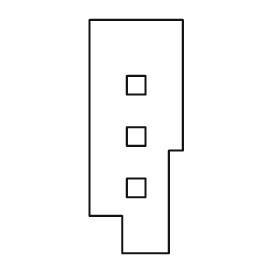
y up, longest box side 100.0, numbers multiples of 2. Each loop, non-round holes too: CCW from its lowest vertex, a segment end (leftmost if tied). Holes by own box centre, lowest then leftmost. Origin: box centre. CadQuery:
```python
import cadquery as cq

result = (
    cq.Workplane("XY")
    .moveTo(-6.0, -50.0)
    .lineTo(14.0, -50.0)
    .lineTo(14.0, -6.0)
    .lineTo(20.0, -6.0)
    .lineTo(20.0, 50.0)
    .lineTo(-20.0, 50.0)
    .lineTo(-20.0, -34.0)
    .lineTo(-6.0, -34.0)
    .close()
    .moveTo(-4.0, -26.0)
    .lineTo(4.0, -26.0)
    .lineTo(4.0, -18.0)
    .lineTo(-4.0, -18.0)
    .close()
    .moveTo(-4.0, -4.0)
    .lineTo(4.0, -4.0)
    .lineTo(4.0, 4.0)
    .lineTo(-4.0, 4.0)
    .close()
    .moveTo(-4.0, 18.0)
    .lineTo(4.0, 18.0)
    .lineTo(4.0, 26.0)
    .lineTo(-4.0, 26.0)
    .close()
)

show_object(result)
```